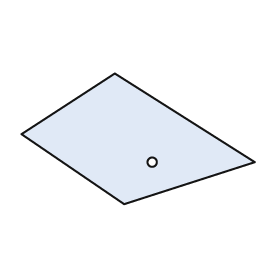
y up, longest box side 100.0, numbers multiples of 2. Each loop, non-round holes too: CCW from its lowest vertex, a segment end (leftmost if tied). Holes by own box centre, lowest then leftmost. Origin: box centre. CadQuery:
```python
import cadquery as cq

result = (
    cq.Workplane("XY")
    .moveTo(-6.0, -28.0)
    .lineTo(50.0, -10.0)
    .lineTo(-10.0, 28.0)
    .lineTo(-50.0, 2.0)
    .close()
    .moveTo(6.0, -10.0)
    .circle(2.0)
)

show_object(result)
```